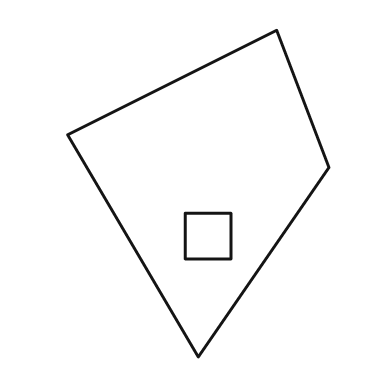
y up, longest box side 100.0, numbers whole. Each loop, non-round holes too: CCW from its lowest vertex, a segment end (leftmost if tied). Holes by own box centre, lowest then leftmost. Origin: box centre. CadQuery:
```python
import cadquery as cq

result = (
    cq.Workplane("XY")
    .moveTo(0.0, -50.0)
    .lineTo(40.0, 8.0)
    .lineTo(24.0, 50.0)
    .lineTo(-40.0, 18.0)
    .close()
    .moveTo(-4.0, -20.0)
    .lineTo(10.0, -20.0)
    .lineTo(10.0, -6.0)
    .lineTo(-4.0, -6.0)
    .close()
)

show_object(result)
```